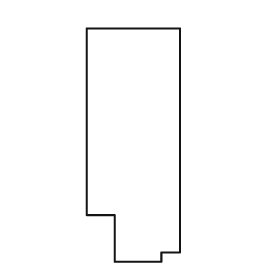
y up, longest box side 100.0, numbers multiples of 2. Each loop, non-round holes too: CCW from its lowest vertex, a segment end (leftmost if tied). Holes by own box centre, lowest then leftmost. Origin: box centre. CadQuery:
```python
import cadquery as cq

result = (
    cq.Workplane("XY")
    .moveTo(-8.0, -50.0)
    .lineTo(12.0, -50.0)
    .lineTo(12.0, -46.0)
    .lineTo(20.0, -46.0)
    .lineTo(20.0, 50.0)
    .lineTo(-20.0, 50.0)
    .lineTo(-20.0, -30.0)
    .lineTo(-8.0, -30.0)
    .close()
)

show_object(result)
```